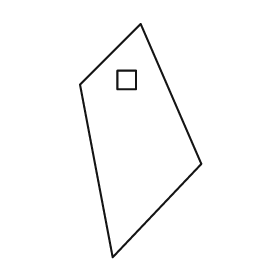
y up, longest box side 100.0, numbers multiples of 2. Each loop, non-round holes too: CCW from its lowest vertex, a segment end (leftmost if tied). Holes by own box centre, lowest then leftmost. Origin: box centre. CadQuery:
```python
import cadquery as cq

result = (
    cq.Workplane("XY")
    .moveTo(-12.0, -50.0)
    .lineTo(26.0, -10.0)
    .lineTo(0.0, 50.0)
    .lineTo(-26.0, 24.0)
    .close()
    .moveTo(-10.0, 22.0)
    .lineTo(-2.0, 22.0)
    .lineTo(-2.0, 30.0)
    .lineTo(-10.0, 30.0)
    .close()
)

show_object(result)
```